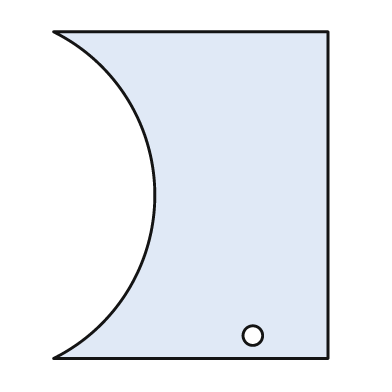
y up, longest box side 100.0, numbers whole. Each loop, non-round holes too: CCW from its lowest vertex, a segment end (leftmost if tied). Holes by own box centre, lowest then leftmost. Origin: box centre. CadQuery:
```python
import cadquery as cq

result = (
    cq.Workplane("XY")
    .moveTo(-42.0, -50.0)
    .lineTo(42.0, -50.0)
    .lineTo(42.0, 50.0)
    .lineTo(-42.0, 50.0)
    .threePointArc((-11.0, 0.0), (-42.0, -50.0))
    .close()
    .moveTo(19.0, -43.0)
    .circle(3.0)
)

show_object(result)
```